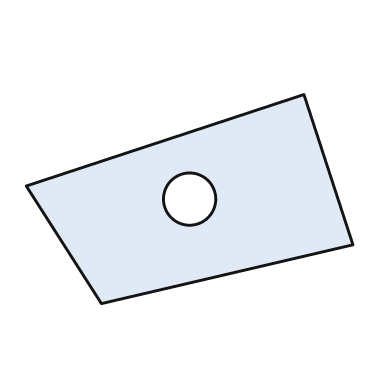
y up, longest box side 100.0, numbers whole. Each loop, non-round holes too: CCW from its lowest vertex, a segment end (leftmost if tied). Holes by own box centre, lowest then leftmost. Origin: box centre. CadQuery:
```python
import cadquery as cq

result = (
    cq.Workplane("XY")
    .moveTo(-27.0, -32.0)
    .lineTo(50.0, -14.0)
    .lineTo(35.0, 32.0)
    .lineTo(-50.0, 4.0)
    .close()
    .moveTo(0.0, 0.0)
    .circle(8.0)
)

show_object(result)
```